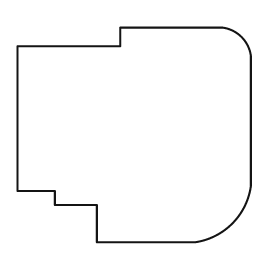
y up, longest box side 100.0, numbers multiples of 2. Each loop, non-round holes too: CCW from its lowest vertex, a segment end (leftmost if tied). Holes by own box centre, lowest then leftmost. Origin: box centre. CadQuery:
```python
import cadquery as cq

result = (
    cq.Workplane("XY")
    .moveTo(-16.0, -46.0)
    .lineTo(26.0, -46.0)
    .threePointArc((42.0, -38.0), (50.0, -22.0))
    .lineTo(50.0, 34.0)
    .threePointArc((46.0, 42.0), (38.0, 46.0))
    .lineTo(-6.0, 46.0)
    .lineTo(-6.0, 38.0)
    .lineTo(-50.0, 38.0)
    .lineTo(-50.0, -24.0)
    .lineTo(-34.0, -24.0)
    .lineTo(-34.0, -30.0)
    .lineTo(-16.0, -30.0)
    .close()
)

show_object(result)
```